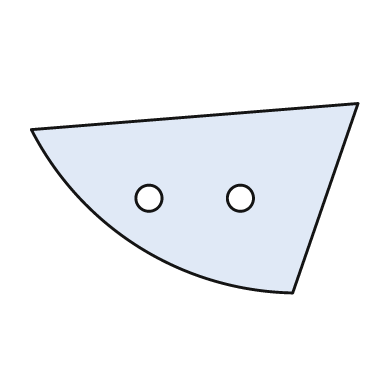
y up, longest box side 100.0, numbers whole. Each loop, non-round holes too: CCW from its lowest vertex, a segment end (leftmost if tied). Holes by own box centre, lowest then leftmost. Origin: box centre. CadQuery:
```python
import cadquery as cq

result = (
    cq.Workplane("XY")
    .moveTo(30.0, -29.0)
    .lineTo(50.0, 29.0)
    .lineTo(-50.0, 21.0)
    .threePointArc((-17.0, -15.0), (30.0, -29.0))
    .close()
    .moveTo(-14.0, 0.0)
    .circle(4.0)
    .moveTo(14.0, 0.0)
    .circle(4.0)
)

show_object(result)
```